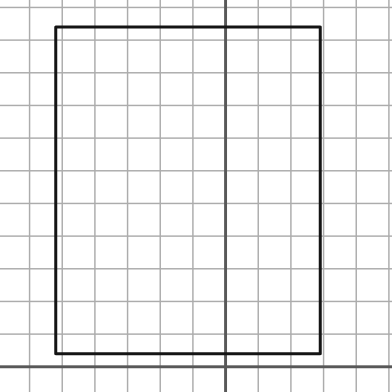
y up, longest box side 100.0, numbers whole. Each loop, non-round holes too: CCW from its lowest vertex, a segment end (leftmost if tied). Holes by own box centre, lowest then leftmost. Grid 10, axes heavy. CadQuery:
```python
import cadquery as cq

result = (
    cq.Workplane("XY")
    .moveTo(-52.0, 4.0)
    .lineTo(29.0, 4.0)
    .lineTo(29.0, 104.0)
    .lineTo(-52.0, 104.0)
    .close()
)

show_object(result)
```